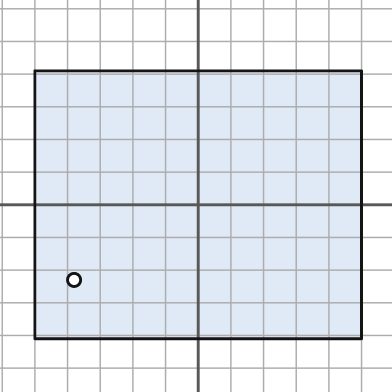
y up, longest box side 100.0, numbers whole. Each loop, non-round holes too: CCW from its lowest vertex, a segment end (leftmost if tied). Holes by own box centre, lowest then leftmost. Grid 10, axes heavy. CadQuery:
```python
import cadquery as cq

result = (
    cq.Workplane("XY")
    .moveTo(-50.0, -41.0)
    .lineTo(50.0, -41.0)
    .lineTo(50.0, 41.0)
    .lineTo(-50.0, 41.0)
    .close()
    .moveTo(-38.0, -23.0)
    .circle(2.0)
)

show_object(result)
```